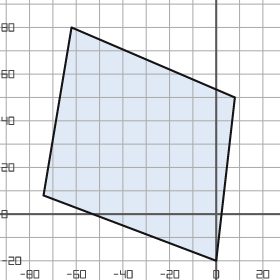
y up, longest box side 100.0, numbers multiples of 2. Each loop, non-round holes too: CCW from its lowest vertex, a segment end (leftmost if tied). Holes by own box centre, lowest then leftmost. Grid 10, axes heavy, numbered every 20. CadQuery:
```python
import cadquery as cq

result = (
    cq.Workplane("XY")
    .moveTo(0.0, -20.0)
    .lineTo(8.0, 50.0)
    .lineTo(-62.0, 80.0)
    .lineTo(-74.0, 8.0)
    .close()
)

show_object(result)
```